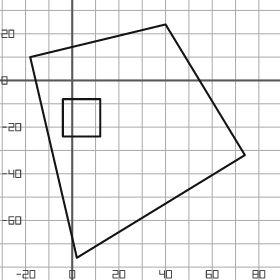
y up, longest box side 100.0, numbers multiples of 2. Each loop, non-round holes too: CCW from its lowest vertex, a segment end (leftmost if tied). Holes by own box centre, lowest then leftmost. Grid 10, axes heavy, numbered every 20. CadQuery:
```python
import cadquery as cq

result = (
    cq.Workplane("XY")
    .moveTo(2.0, -76.0)
    .lineTo(74.0, -32.0)
    .lineTo(40.0, 24.0)
    .lineTo(-18.0, 10.0)
    .close()
    .moveTo(-4.0, -24.0)
    .lineTo(12.0, -24.0)
    .lineTo(12.0, -8.0)
    .lineTo(-4.0, -8.0)
    .close()
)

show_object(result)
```